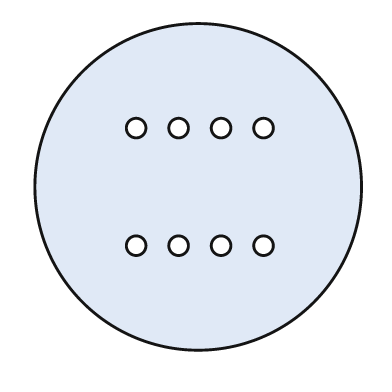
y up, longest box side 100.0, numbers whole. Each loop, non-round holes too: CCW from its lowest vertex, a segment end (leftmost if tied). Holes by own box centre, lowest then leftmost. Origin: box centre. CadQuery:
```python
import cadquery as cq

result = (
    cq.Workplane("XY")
    .moveTo(0.0, 0.0)
    .circle(50.0)
    .moveTo(-19.0, -18.0)
    .circle(3.0)
    .moveTo(-6.0, -18.0)
    .circle(3.0)
    .moveTo(7.0, -18.0)
    .circle(3.0)
    .moveTo(20.0, -18.0)
    .circle(3.0)
    .moveTo(-19.0, 18.0)
    .circle(3.0)
    .moveTo(-6.0, 18.0)
    .circle(3.0)
    .moveTo(7.0, 18.0)
    .circle(3.0)
    .moveTo(20.0, 18.0)
    .circle(3.0)
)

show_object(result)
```